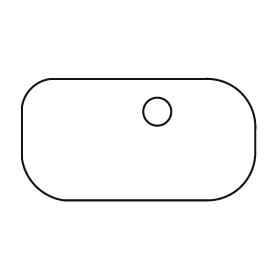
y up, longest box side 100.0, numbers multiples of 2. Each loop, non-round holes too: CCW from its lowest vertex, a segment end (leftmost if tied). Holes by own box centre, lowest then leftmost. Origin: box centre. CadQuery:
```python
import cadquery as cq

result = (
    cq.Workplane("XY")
    .moveTo(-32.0, -26.0)
    .lineTo(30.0, -26.0)
    .threePointArc((44.0, -20.0), (50.0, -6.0))
    .lineTo(50.0, 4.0)
    .threePointArc((44.0, 20.0), (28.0, 26.0))
    .lineTo(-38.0, 26.0)
    .threePointArc((-46.0, 22.0), (-50.0, 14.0))
    .lineTo(-50.0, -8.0)
    .threePointArc((-44.0, -20.0), (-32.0, -26.0))
    .close()
    .moveTo(8.0, 12.0)
    .circle(6.0)
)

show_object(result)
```